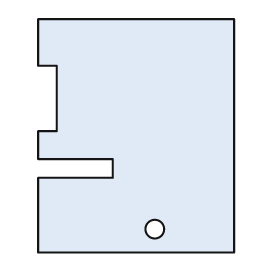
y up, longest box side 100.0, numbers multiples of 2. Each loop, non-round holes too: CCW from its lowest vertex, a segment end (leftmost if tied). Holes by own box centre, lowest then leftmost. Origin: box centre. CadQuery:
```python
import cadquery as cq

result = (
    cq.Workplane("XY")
    .moveTo(-42.0, -50.0)
    .lineTo(42.0, -50.0)
    .lineTo(42.0, 50.0)
    .lineTo(-42.0, 50.0)
    .lineTo(-42.0, 30.0)
    .lineTo(-34.0, 30.0)
    .lineTo(-34.0, 2.0)
    .lineTo(-42.0, 2.0)
    .lineTo(-42.0, -10.0)
    .lineTo(-10.0, -10.0)
    .lineTo(-10.0, -18.0)
    .lineTo(-42.0, -18.0)
    .close()
    .moveTo(8.0, -40.0)
    .circle(4.0)
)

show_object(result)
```